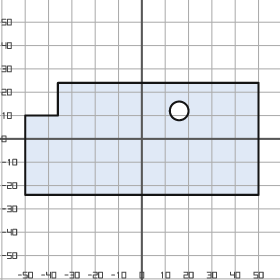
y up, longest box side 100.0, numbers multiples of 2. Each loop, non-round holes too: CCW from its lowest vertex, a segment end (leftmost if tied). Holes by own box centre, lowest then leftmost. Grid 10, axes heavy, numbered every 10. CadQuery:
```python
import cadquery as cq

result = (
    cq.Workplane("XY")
    .moveTo(-50.0, -24.0)
    .lineTo(50.0, -24.0)
    .lineTo(50.0, 24.0)
    .lineTo(-36.0, 24.0)
    .lineTo(-36.0, 10.0)
    .lineTo(-50.0, 10.0)
    .close()
    .moveTo(16.0, 12.0)
    .circle(4.0)
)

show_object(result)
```